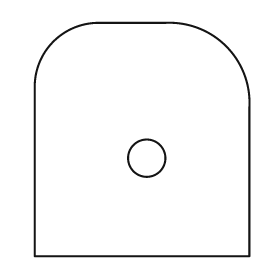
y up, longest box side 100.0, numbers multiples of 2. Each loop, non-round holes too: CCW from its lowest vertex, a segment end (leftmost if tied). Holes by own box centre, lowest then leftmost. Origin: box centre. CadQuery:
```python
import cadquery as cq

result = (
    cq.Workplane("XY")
    .moveTo(-46.0, -50.0)
    .lineTo(46.0, -50.0)
    .lineTo(46.0, 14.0)
    .threePointArc((36.0, 40.0), (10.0, 50.0))
    .lineTo(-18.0, 50.0)
    .threePointArc((-38.0, 42.0), (-46.0, 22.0))
    .close()
    .moveTo(2.0, -8.0)
    .circle(8.0)
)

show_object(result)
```